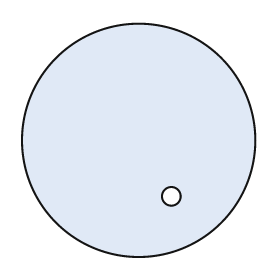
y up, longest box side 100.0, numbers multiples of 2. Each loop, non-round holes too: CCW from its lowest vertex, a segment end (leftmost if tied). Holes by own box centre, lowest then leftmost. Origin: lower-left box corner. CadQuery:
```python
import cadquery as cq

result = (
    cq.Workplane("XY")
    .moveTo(50.0, 50.0)
    .circle(50.0)
    .moveTo(64.0, 26.0)
    .circle(4.0)
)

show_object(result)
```